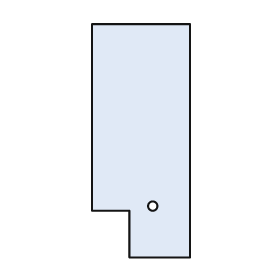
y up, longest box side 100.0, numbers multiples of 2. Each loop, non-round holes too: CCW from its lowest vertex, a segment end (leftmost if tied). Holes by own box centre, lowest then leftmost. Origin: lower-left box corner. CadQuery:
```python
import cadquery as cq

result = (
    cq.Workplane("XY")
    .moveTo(16.0, 0.0)
    .lineTo(42.0, 0.0)
    .lineTo(42.0, 100.0)
    .lineTo(0.0, 100.0)
    .lineTo(0.0, 20.0)
    .lineTo(16.0, 20.0)
    .close()
    .moveTo(26.0, 22.0)
    .circle(2.0)
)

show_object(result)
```